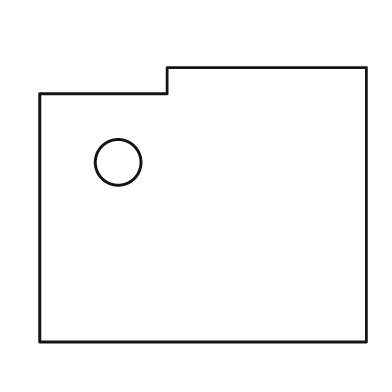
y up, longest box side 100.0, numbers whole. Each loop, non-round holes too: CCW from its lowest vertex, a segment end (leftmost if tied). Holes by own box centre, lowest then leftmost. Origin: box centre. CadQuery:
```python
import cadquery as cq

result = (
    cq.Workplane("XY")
    .moveTo(-50.0, -42.0)
    .lineTo(50.0, -42.0)
    .lineTo(50.0, 42.0)
    .lineTo(-11.0, 42.0)
    .lineTo(-11.0, 34.0)
    .lineTo(-50.0, 34.0)
    .close()
    .moveTo(-26.0, 13.0)
    .circle(7.0)
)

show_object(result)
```